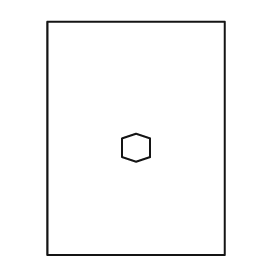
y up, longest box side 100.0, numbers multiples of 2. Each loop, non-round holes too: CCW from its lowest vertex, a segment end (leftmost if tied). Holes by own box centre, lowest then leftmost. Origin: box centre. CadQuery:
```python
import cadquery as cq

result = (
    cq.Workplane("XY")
    .moveTo(-38.0, -50.0)
    .lineTo(38.0, -50.0)
    .lineTo(38.0, 50.0)
    .lineTo(-38.0, 50.0)
    .close()
    .moveTo(0.0, -10.0)
    .lineTo(6.0, -8.0)
    .lineTo(6.0, 0.0)
    .lineTo(0.0, 2.0)
    .lineTo(-6.0, 0.0)
    .lineTo(-6.0, -8.0)
    .close()
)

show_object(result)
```